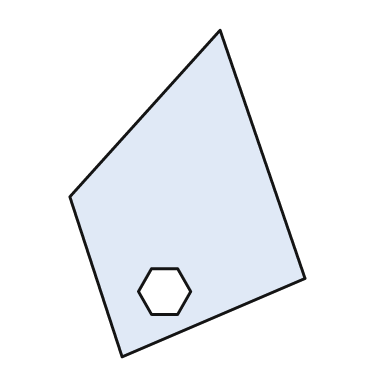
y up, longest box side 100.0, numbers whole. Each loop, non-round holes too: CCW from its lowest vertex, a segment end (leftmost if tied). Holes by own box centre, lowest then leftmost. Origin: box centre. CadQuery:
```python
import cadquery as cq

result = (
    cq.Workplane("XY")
    .moveTo(-20.0, -50.0)
    .lineTo(36.0, -26.0)
    .lineTo(10.0, 50.0)
    .lineTo(-36.0, -1.0)
    .close()
    .moveTo(-11.0, -37.0)
    .lineTo(-3.0, -37.0)
    .lineTo(1.0, -30.0)
    .lineTo(-3.0, -23.0)
    .lineTo(-11.0, -23.0)
    .lineTo(-15.0, -30.0)
    .close()
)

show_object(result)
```